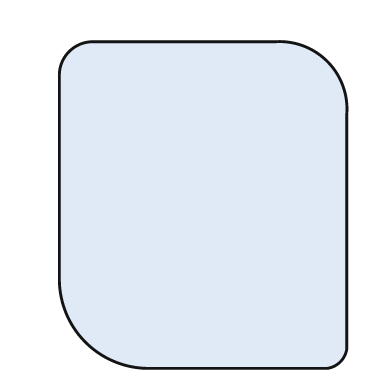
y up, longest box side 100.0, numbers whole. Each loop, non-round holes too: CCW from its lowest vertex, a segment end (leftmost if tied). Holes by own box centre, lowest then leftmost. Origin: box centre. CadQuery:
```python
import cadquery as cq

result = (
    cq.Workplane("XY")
    .moveTo(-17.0, -50.0)
    .lineTo(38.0, -50.0)
    .threePointArc((42.0, -48.0), (44.0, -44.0))
    .lineTo(44.0, 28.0)
    .threePointArc((38.0, 44.0), (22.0, 50.0))
    .lineTo(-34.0, 50.0)
    .threePointArc((-41.0, 47.0), (-44.0, 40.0))
    .lineTo(-44.0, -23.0)
    .threePointArc((-36.0, -42.0), (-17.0, -50.0))
    .close()
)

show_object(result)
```